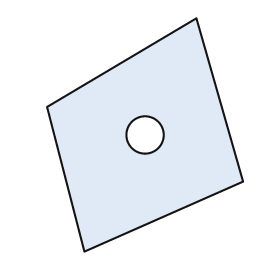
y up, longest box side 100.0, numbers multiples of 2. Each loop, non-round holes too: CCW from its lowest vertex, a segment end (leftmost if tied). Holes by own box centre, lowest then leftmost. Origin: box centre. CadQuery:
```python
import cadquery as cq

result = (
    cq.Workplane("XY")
    .moveTo(-26.0, -50.0)
    .lineTo(42.0, -20.0)
    .lineTo(22.0, 50.0)
    .lineTo(-42.0, 12.0)
    .close()
    .moveTo(0.0, 0.0)
    .circle(8.0)
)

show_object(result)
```